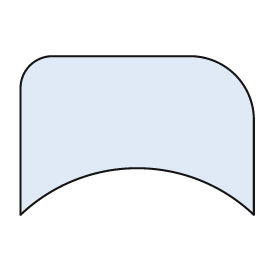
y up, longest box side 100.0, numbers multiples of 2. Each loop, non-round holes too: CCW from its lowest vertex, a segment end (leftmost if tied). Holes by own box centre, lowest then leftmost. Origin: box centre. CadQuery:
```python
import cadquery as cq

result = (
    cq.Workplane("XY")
    .moveTo(-50.0, -34.0)
    .threePointArc((0.0, -14.0), (50.0, -34.0))
    .lineTo(50.0, 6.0)
    .threePointArc((42.0, 26.0), (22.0, 34.0))
    .lineTo(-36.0, 34.0)
    .threePointArc((-46.0, 30.0), (-50.0, 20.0))
    .close()
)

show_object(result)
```